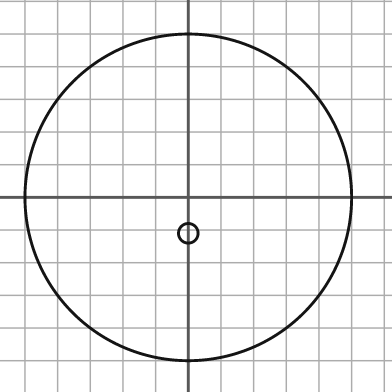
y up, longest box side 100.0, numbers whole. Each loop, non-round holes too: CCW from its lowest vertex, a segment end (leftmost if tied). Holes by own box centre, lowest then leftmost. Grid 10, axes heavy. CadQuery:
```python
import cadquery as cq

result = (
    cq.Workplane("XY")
    .moveTo(0.0, 0.0)
    .circle(50.0)
    .moveTo(0.0, -11.0)
    .circle(3.0)
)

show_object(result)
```